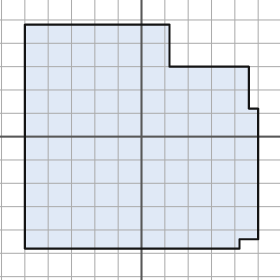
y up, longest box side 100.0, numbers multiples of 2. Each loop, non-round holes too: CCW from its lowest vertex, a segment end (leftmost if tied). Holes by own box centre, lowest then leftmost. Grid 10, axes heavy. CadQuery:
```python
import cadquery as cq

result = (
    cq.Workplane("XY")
    .moveTo(-50.0, -48.0)
    .lineTo(42.0, -48.0)
    .lineTo(42.0, -44.0)
    .lineTo(50.0, -44.0)
    .lineTo(50.0, 12.0)
    .lineTo(46.0, 12.0)
    .lineTo(46.0, 30.0)
    .lineTo(12.0, 30.0)
    .lineTo(12.0, 48.0)
    .lineTo(-50.0, 48.0)
    .close()
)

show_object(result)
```